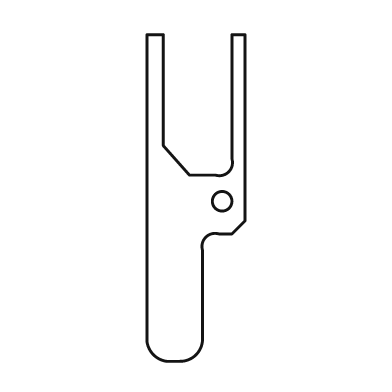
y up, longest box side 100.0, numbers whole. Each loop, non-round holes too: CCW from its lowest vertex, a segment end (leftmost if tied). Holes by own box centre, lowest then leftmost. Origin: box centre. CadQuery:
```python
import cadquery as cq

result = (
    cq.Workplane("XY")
    .moveTo(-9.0, -50.0)
    .lineTo(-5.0, -50.0)
    .threePointArc((0.0, -48.0), (2.0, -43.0))
    .lineTo(2.0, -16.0)
    .threePointArc((3.0, -12.0), (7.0, -11.0))
    .lineTo(11.0, -11.0)
    .lineTo(15.0, -7.0)
    .lineTo(15.0, 50.0)
    .lineTo(11.0, 50.0)
    .lineTo(11.0, 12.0)
    .threePointArc((10.0, 8.0), (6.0, 7.0))
    .lineTo(-2.0, 7.0)
    .lineTo(-10.0, 16.0)
    .lineTo(-10.0, 50.0)
    .lineTo(-15.0, 50.0)
    .lineTo(-15.0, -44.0)
    .threePointArc((-13.0, -48.0), (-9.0, -50.0))
    .close()
    .moveTo(8.0, -1.0)
    .circle(3.0)
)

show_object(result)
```